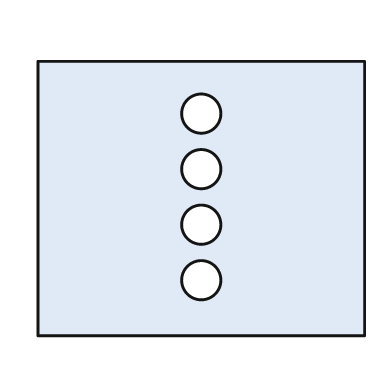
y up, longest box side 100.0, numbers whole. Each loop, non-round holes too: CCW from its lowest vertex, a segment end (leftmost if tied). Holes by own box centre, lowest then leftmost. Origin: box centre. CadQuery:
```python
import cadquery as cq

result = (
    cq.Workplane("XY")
    .moveTo(-50.0, -42.0)
    .lineTo(50.0, -42.0)
    .lineTo(50.0, 42.0)
    .lineTo(-50.0, 42.0)
    .close()
    .moveTo(0.0, -25.0)
    .circle(6.0)
    .moveTo(0.0, -8.0)
    .circle(6.0)
    .moveTo(0.0, 9.0)
    .circle(6.0)
    .moveTo(0.0, 26.0)
    .circle(6.0)
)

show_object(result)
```